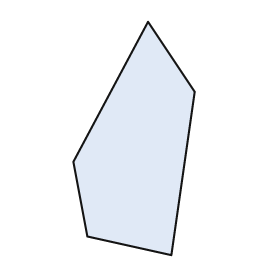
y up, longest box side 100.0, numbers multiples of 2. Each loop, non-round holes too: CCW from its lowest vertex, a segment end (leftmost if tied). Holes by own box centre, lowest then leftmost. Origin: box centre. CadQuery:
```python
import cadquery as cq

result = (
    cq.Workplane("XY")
    .moveTo(16.0, -50.0)
    .lineTo(26.0, 20.0)
    .lineTo(6.0, 50.0)
    .lineTo(-26.0, -10.0)
    .lineTo(-20.0, -42.0)
    .close()
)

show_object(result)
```